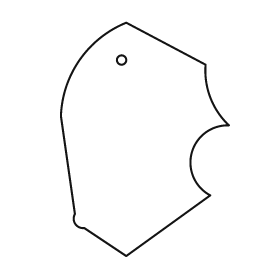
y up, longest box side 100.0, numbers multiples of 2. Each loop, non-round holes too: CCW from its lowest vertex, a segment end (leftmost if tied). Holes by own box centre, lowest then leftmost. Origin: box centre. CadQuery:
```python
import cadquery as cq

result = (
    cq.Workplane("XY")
    .moveTo(-8.0, -50.0)
    .lineTo(28.0, -24.0)
    .threePointArc((20.0, -6.0), (36.0, 6.0))
    .threePointArc((28.0, 18.0), (26.0, 32.0))
    .lineTo(-8.0, 50.0)
    .threePointArc((-28.0, 34.0), (-36.0, 10.0))
    .lineTo(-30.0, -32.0)
    .threePointArc((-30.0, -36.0), (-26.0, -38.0))
    .close()
    .moveTo(-10.0, 34.0)
    .circle(2.0)
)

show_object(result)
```